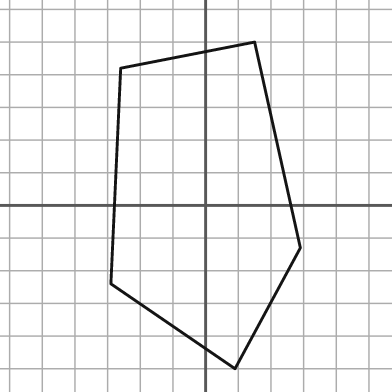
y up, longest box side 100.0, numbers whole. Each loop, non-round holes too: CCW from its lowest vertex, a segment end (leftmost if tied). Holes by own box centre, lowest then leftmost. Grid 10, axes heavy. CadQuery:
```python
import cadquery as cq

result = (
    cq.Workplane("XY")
    .moveTo(9.0, -50.0)
    .lineTo(29.0, -13.0)
    .lineTo(15.0, 50.0)
    .lineTo(-26.0, 42.0)
    .lineTo(-29.0, -24.0)
    .close()
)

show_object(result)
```